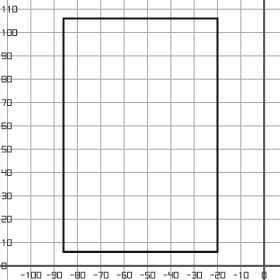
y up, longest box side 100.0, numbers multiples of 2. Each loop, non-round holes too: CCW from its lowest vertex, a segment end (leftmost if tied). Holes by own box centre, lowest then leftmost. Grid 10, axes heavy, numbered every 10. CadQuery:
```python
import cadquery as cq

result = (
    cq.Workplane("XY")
    .moveTo(-86.0, 6.0)
    .lineTo(-20.0, 6.0)
    .lineTo(-20.0, 106.0)
    .lineTo(-86.0, 106.0)
    .close()
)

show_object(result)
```